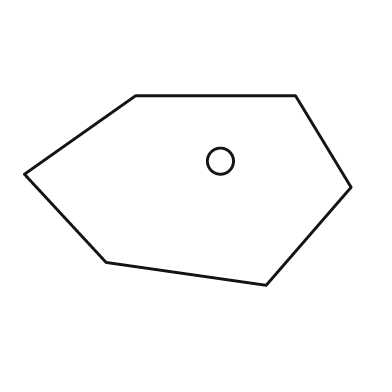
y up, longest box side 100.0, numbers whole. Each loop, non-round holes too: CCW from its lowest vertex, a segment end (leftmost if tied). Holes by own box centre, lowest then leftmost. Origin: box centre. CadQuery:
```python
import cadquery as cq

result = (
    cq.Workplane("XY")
    .moveTo(24.0, -29.0)
    .lineTo(50.0, 1.0)
    .lineTo(33.0, 29.0)
    .lineTo(-16.0, 29.0)
    .lineTo(-50.0, 5.0)
    .lineTo(-25.0, -22.0)
    .close()
    .moveTo(10.0, 9.0)
    .circle(4.0)
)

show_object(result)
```